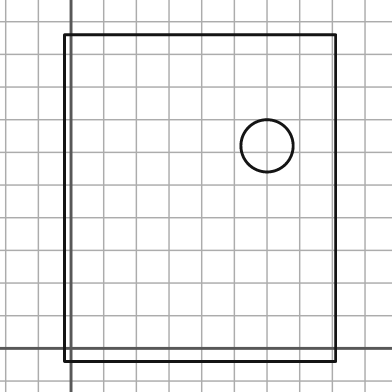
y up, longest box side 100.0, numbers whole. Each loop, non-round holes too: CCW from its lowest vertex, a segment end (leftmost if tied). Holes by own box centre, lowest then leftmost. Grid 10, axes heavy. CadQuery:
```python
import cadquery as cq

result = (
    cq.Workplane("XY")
    .moveTo(-2.0, -4.0)
    .lineTo(81.0, -4.0)
    .lineTo(81.0, 96.0)
    .lineTo(-2.0, 96.0)
    .close()
    .moveTo(60.0, 62.0)
    .circle(8.0)
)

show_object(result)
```